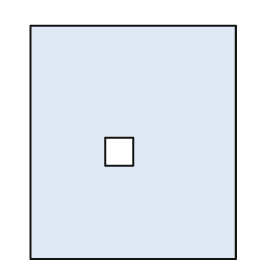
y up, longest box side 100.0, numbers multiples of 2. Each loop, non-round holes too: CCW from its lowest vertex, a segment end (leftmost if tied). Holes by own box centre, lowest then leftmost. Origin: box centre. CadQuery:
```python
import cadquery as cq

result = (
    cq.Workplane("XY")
    .moveTo(-44.0, -50.0)
    .lineTo(44.0, -50.0)
    .lineTo(44.0, 50.0)
    .lineTo(-44.0, 50.0)
    .close()
    .moveTo(-12.0, -10.0)
    .lineTo(0.0, -10.0)
    .lineTo(0.0, 2.0)
    .lineTo(-12.0, 2.0)
    .close()
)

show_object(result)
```